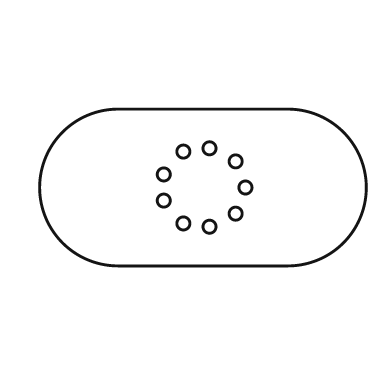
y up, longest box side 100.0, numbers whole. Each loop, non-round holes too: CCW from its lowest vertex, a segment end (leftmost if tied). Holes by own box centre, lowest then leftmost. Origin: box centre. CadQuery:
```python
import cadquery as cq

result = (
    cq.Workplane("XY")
    .moveTo(-26.0, -24.0)
    .lineTo(26.0, -24.0)
    .threePointArc((50.0, 0.0), (26.0, 24.0))
    .lineTo(-26.0, 24.0)
    .threePointArc((-50.0, 0.0), (-26.0, -24.0))
    .close()
    .moveTo(2.0, -12.0)
    .circle(2.0)
    .moveTo(-6.0, -11.0)
    .circle(2.0)
    .moveTo(10.0, -8.0)
    .circle(2.0)
    .moveTo(-12.0, -4.0)
    .circle(2.0)
    .moveTo(13.0, 0.0)
    .circle(2.0)
    .moveTo(-12.0, 4.0)
    .circle(2.0)
    .moveTo(10.0, 8.0)
    .circle(2.0)
    .moveTo(-6.0, 11.0)
    .circle(2.0)
    .moveTo(2.0, 12.0)
    .circle(2.0)
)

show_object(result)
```